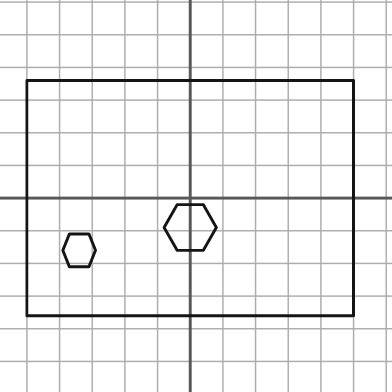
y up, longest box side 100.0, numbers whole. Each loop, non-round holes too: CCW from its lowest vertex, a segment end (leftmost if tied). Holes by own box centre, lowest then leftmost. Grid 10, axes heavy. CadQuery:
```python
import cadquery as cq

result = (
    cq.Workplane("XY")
    .moveTo(-50.0, -36.0)
    .lineTo(50.0, -36.0)
    .lineTo(50.0, 36.0)
    .lineTo(-50.0, 36.0)
    .close()
    .moveTo(-37.0, -21.0)
    .lineTo(-31.0, -21.0)
    .lineTo(-29.0, -16.0)
    .lineTo(-31.0, -11.0)
    .lineTo(-37.0, -11.0)
    .lineTo(-39.0, -16.0)
    .close()
    .moveTo(-4.0, -16.0)
    .lineTo(4.0, -16.0)
    .lineTo(8.0, -9.0)
    .lineTo(4.0, -2.0)
    .lineTo(-4.0, -2.0)
    .lineTo(-8.0, -9.0)
    .close()
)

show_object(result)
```